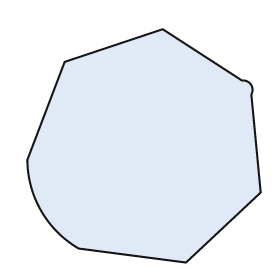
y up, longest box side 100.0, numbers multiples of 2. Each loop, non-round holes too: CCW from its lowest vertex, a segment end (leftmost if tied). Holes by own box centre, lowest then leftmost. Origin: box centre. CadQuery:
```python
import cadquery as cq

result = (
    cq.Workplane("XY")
    .moveTo(18.0, -50.0)
    .lineTo(50.0, -20.0)
    .lineTo(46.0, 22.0)
    .threePointArc((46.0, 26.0), (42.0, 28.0))
    .lineTo(8.0, 50.0)
    .lineTo(-34.0, 36.0)
    .lineTo(-50.0, -6.0)
    .threePointArc((-44.0, -28.0), (-28.0, -44.0))
    .close()
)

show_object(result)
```